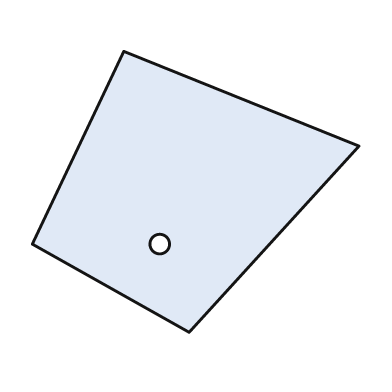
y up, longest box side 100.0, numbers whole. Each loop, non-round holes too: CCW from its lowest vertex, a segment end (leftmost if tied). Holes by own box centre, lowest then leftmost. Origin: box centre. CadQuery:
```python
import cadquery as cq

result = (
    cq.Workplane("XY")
    .moveTo(-2.0, -43.0)
    .lineTo(50.0, 14.0)
    .lineTo(-22.0, 43.0)
    .lineTo(-50.0, -16.0)
    .close()
    .moveTo(-11.0, -16.0)
    .circle(3.0)
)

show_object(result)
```